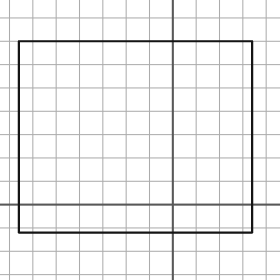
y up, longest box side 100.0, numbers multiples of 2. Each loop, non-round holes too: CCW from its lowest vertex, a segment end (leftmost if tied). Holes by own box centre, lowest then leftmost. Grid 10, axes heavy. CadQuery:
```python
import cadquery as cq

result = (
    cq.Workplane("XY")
    .moveTo(-66.0, -12.0)
    .lineTo(34.0, -12.0)
    .lineTo(34.0, 70.0)
    .lineTo(-66.0, 70.0)
    .close()
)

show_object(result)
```